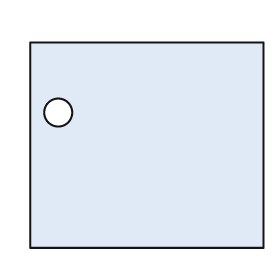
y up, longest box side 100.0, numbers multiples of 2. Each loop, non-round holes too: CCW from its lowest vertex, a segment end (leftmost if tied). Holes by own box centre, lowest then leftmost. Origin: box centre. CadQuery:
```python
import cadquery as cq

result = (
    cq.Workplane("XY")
    .moveTo(-50.0, -44.0)
    .lineTo(50.0, -44.0)
    .lineTo(50.0, 44.0)
    .lineTo(-50.0, 44.0)
    .close()
    .moveTo(-38.0, 14.0)
    .circle(6.0)
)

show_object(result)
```